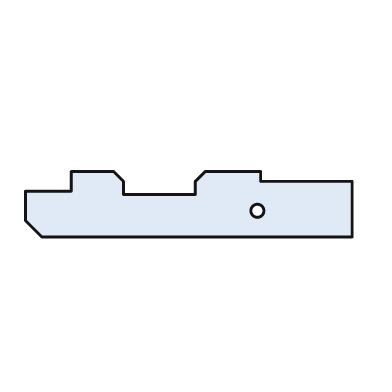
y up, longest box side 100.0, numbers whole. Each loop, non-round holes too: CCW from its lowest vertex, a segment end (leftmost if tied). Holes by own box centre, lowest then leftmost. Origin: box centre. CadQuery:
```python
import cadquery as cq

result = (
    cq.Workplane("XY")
    .moveTo(-45.0, -10.0)
    .lineTo(50.0, -10.0)
    .lineTo(50.0, 7.0)
    .lineTo(22.0, 7.0)
    .lineTo(22.0, 10.0)
    .lineTo(5.0, 10.0)
    .lineTo(2.0, 7.0)
    .lineTo(2.0, 3.0)
    .lineTo(-20.0, 3.0)
    .lineTo(-20.0, 7.0)
    .lineTo(-23.0, 10.0)
    .lineTo(-36.0, 10.0)
    .lineTo(-36.0, 4.0)
    .lineTo(-50.0, 4.0)
    .lineTo(-50.0, -5.0)
    .close()
    .moveTo(21.0, -2.0)
    .circle(2.0)
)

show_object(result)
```